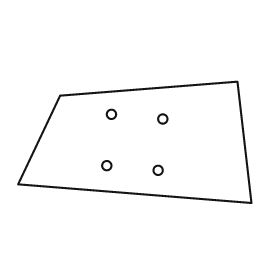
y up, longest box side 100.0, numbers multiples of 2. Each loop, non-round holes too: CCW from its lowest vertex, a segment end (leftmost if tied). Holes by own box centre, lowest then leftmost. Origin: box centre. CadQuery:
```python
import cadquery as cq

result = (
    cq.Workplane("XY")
    .moveTo(50.0, -26.0)
    .lineTo(44.0, 26.0)
    .lineTo(-32.0, 20.0)
    .lineTo(-50.0, -18.0)
    .close()
    .moveTo(10.0, -12.0)
    .circle(2.0)
    .moveTo(-12.0, -10.0)
    .circle(2.0)
    .moveTo(12.0, 10.0)
    .circle(2.0)
    .moveTo(-10.0, 12.0)
    .circle(2.0)
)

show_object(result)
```